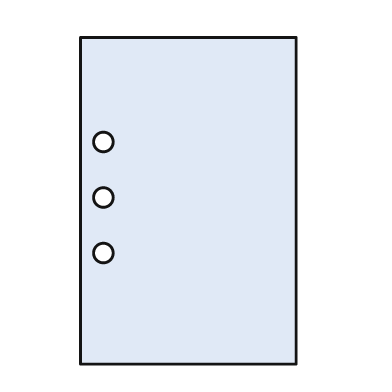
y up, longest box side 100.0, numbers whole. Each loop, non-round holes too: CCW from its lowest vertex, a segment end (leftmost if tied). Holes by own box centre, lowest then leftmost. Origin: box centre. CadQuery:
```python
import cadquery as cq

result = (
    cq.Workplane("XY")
    .moveTo(-33.0, -50.0)
    .lineTo(33.0, -50.0)
    .lineTo(33.0, 50.0)
    .lineTo(-33.0, 50.0)
    .close()
    .moveTo(-26.0, -16.0)
    .circle(3.0)
    .moveTo(-26.0, 1.0)
    .circle(3.0)
    .moveTo(-26.0, 18.0)
    .circle(3.0)
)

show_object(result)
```